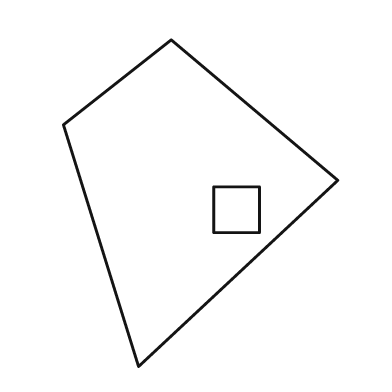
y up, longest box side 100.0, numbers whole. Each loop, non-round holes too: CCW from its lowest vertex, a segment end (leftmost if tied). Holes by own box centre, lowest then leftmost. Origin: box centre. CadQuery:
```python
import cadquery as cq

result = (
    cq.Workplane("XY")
    .moveTo(-19.0, -50.0)
    .lineTo(42.0, 7.0)
    .lineTo(-9.0, 50.0)
    .lineTo(-42.0, 24.0)
    .close()
    .moveTo(4.0, -9.0)
    .lineTo(18.0, -9.0)
    .lineTo(18.0, 5.0)
    .lineTo(4.0, 5.0)
    .close()
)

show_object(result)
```